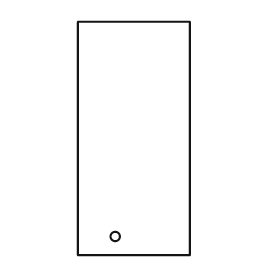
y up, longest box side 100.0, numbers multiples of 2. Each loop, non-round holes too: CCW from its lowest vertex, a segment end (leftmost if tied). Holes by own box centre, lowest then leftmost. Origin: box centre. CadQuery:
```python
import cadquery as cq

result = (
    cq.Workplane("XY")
    .moveTo(-24.0, -50.0)
    .lineTo(24.0, -50.0)
    .lineTo(24.0, 50.0)
    .lineTo(-24.0, 50.0)
    .close()
    .moveTo(-8.0, -42.0)
    .circle(2.0)
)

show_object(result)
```